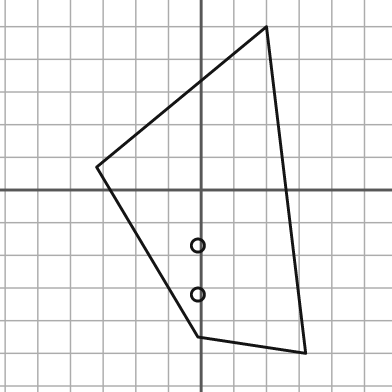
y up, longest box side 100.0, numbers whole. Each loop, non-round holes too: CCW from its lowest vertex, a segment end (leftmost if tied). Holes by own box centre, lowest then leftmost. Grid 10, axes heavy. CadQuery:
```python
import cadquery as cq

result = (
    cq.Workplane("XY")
    .moveTo(32.0, -50.0)
    .lineTo(20.0, 50.0)
    .lineTo(-32.0, 7.0)
    .lineTo(-1.0, -45.0)
    .close()
    .moveTo(-1.0, -32.0)
    .circle(2.0)
    .moveTo(-1.0, -17.0)
    .circle(2.0)
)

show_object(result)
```